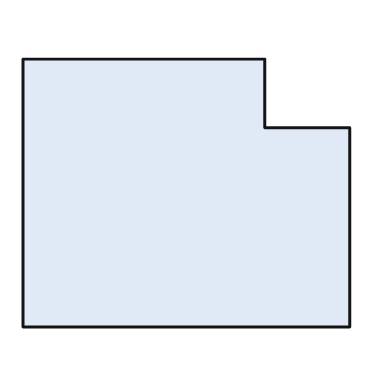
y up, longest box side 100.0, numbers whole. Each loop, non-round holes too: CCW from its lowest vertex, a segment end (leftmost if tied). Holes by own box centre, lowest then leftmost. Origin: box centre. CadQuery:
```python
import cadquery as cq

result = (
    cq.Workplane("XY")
    .moveTo(-50.0, -41.0)
    .lineTo(50.0, -41.0)
    .lineTo(50.0, 20.0)
    .lineTo(24.0, 20.0)
    .lineTo(24.0, 41.0)
    .lineTo(-50.0, 41.0)
    .close()
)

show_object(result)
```